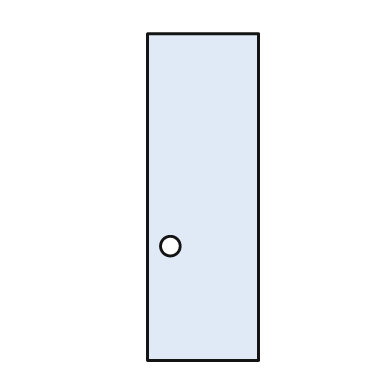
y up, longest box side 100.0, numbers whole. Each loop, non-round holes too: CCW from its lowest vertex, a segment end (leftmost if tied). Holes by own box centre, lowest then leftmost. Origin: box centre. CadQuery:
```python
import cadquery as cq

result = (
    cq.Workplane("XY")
    .moveTo(-17.0, -50.0)
    .lineTo(17.0, -50.0)
    .lineTo(17.0, 50.0)
    .lineTo(-17.0, 50.0)
    .close()
    .moveTo(-10.0, -15.0)
    .circle(3.0)
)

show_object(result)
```